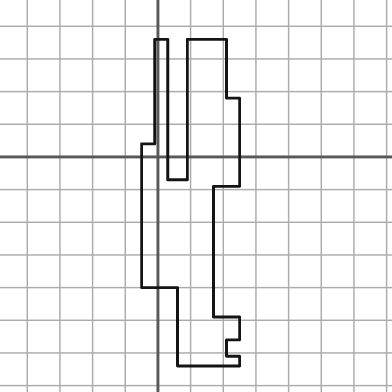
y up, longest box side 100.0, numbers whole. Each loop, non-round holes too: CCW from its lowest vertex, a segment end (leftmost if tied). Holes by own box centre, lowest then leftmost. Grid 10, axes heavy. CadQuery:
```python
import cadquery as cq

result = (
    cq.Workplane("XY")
    .moveTo(6.0, -64.0)
    .lineTo(25.0, -64.0)
    .lineTo(25.0, -61.0)
    .lineTo(21.0, -61.0)
    .lineTo(21.0, -56.0)
    .lineTo(25.0, -56.0)
    .lineTo(25.0, -49.0)
    .lineTo(17.0, -49.0)
    .lineTo(17.0, -9.0)
    .lineTo(25.0, -9.0)
    .lineTo(25.0, 18.0)
    .lineTo(21.0, 18.0)
    .lineTo(21.0, 36.0)
    .lineTo(9.0, 36.0)
    .lineTo(9.0, -7.0)
    .lineTo(3.0, -7.0)
    .lineTo(3.0, 36.0)
    .lineTo(-1.0, 36.0)
    .lineTo(-1.0, 4.0)
    .lineTo(-5.0, 4.0)
    .lineTo(-5.0, -40.0)
    .lineTo(6.0, -40.0)
    .close()
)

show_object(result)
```